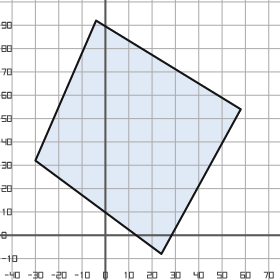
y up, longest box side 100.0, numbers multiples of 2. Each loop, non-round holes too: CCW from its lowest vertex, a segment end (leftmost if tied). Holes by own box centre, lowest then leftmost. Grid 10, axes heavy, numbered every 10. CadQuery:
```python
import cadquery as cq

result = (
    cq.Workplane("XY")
    .moveTo(24.0, -8.0)
    .lineTo(58.0, 54.0)
    .lineTo(-4.0, 92.0)
    .lineTo(-30.0, 32.0)
    .close()
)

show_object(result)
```